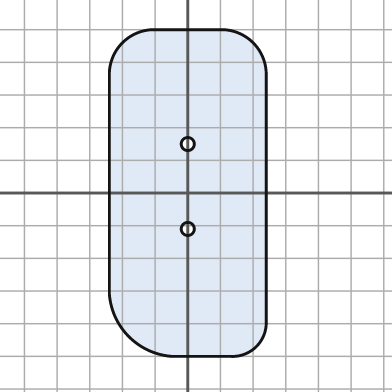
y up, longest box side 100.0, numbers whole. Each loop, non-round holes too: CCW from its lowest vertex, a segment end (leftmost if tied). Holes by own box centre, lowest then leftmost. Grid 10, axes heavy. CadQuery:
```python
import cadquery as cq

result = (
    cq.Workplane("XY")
    .moveTo(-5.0, -50.0)
    .lineTo(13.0, -50.0)
    .threePointArc((21.0, -47.0), (24.0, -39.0))
    .lineTo(24.0, 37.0)
    .threePointArc((20.0, 46.0), (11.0, 50.0))
    .lineTo(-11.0, 50.0)
    .threePointArc((-20.0, 46.0), (-24.0, 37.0))
    .lineTo(-24.0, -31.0)
    .threePointArc((-18.0, -44.0), (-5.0, -50.0))
    .close()
    .moveTo(0.0, -11.0)
    .circle(2.0)
    .moveTo(0.0, 15.0)
    .circle(2.0)
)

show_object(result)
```